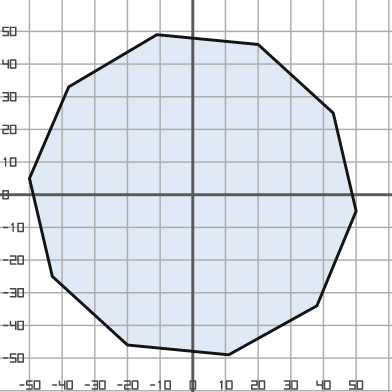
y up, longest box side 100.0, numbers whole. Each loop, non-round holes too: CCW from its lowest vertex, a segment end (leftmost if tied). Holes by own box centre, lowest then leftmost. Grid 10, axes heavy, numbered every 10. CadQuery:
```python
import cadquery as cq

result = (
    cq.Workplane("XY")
    .moveTo(11.0, -49.0)
    .lineTo(38.0, -34.0)
    .lineTo(50.0, -5.0)
    .lineTo(43.0, 25.0)
    .lineTo(20.0, 46.0)
    .lineTo(-11.0, 49.0)
    .lineTo(-38.0, 33.0)
    .lineTo(-50.0, 5.0)
    .lineTo(-43.0, -25.0)
    .lineTo(-20.0, -46.0)
    .close()
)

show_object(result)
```